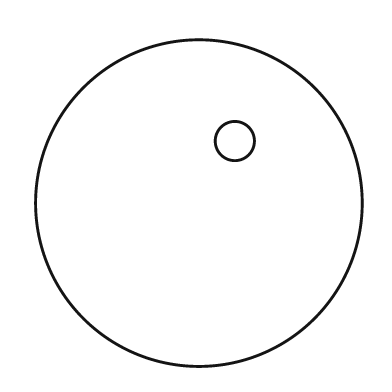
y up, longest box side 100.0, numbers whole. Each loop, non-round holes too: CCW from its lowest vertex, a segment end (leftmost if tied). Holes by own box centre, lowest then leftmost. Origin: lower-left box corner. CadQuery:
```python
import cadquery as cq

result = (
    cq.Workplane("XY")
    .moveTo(50.0, 50.0)
    .circle(50.0)
    .moveTo(61.0, 69.0)
    .circle(6.0)
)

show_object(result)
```